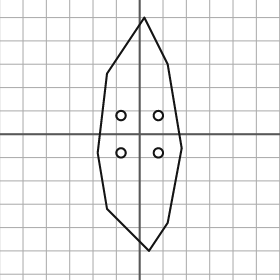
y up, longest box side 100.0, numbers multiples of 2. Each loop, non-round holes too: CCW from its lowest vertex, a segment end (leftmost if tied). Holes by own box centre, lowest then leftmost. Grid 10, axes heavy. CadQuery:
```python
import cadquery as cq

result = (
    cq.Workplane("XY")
    .moveTo(4.0, -50.0)
    .lineTo(12.0, -38.0)
    .lineTo(18.0, -6.0)
    .lineTo(12.0, 30.0)
    .lineTo(2.0, 50.0)
    .lineTo(-14.0, 26.0)
    .lineTo(-18.0, -8.0)
    .lineTo(-14.0, -32.0)
    .close()
    .moveTo(-8.0, -8.0)
    .circle(2.0)
    .moveTo(8.0, -8.0)
    .circle(2.0)
    .moveTo(-8.0, 8.0)
    .circle(2.0)
    .moveTo(8.0, 8.0)
    .circle(2.0)
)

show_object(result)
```